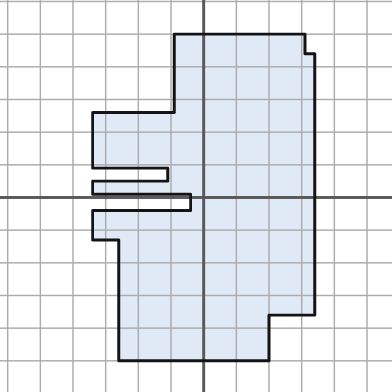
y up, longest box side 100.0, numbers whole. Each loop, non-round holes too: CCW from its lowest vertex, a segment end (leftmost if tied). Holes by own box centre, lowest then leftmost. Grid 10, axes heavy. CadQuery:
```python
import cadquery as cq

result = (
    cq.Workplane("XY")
    .moveTo(-26.0, -50.0)
    .lineTo(20.0, -50.0)
    .lineTo(20.0, -36.0)
    .lineTo(34.0, -36.0)
    .lineTo(34.0, 44.0)
    .lineTo(31.0, 44.0)
    .lineTo(31.0, 50.0)
    .lineTo(-9.0, 50.0)
    .lineTo(-9.0, 26.0)
    .lineTo(-34.0, 26.0)
    .lineTo(-34.0, 9.0)
    .lineTo(-11.0, 9.0)
    .lineTo(-11.0, 5.0)
    .lineTo(-34.0, 5.0)
    .lineTo(-34.0, 1.0)
    .lineTo(-4.0, 1.0)
    .lineTo(-4.0, -4.0)
    .lineTo(-34.0, -4.0)
    .lineTo(-34.0, -13.0)
    .lineTo(-26.0, -13.0)
    .close()
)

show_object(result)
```